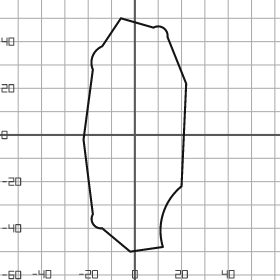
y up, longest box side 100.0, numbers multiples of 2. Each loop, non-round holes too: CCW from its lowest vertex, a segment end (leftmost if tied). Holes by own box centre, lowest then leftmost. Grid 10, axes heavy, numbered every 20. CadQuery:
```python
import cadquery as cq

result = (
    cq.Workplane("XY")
    .moveTo(-2.0, -50.0)
    .lineTo(12.0, -48.0)
    .threePointArc((12.0, -34.0), (20.0, -22.0))
    .lineTo(22.0, 22.0)
    .lineTo(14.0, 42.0)
    .threePointArc((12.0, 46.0), (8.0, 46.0))
    .lineTo(-6.0, 50.0)
    .lineTo(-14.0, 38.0)
    .threePointArc((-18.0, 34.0), (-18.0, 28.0))
    .lineTo(-22.0, -2.0)
    .lineTo(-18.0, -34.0)
    .threePointArc((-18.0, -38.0), (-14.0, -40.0))
    .close()
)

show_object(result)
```